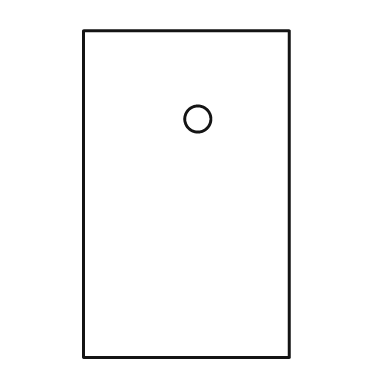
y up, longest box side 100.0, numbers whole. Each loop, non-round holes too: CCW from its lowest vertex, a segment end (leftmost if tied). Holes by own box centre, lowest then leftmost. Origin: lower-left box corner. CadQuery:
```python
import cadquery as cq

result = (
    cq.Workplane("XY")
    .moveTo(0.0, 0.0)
    .lineTo(63.0, 0.0)
    .lineTo(63.0, 100.0)
    .lineTo(0.0, 100.0)
    .close()
    .moveTo(35.0, 73.0)
    .circle(4.0)
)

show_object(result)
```